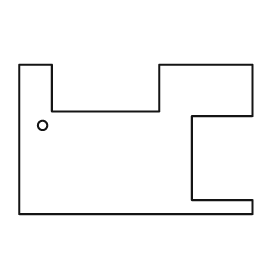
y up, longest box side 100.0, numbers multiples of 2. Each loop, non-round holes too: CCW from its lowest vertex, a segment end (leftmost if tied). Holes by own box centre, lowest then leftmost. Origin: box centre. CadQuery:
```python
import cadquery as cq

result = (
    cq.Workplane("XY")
    .moveTo(-50.0, -32.0)
    .lineTo(50.0, -32.0)
    .lineTo(50.0, -26.0)
    .lineTo(24.0, -26.0)
    .lineTo(24.0, 10.0)
    .lineTo(50.0, 10.0)
    .lineTo(50.0, 32.0)
    .lineTo(10.0, 32.0)
    .lineTo(10.0, 12.0)
    .lineTo(-36.0, 12.0)
    .lineTo(-36.0, 32.0)
    .lineTo(-50.0, 32.0)
    .close()
    .moveTo(-40.0, 6.0)
    .circle(2.0)
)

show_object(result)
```